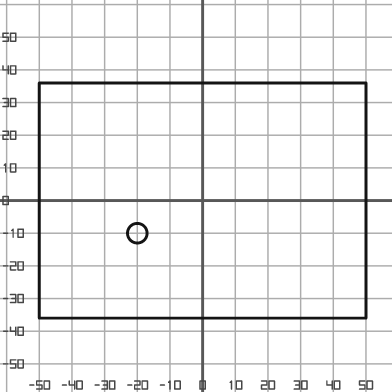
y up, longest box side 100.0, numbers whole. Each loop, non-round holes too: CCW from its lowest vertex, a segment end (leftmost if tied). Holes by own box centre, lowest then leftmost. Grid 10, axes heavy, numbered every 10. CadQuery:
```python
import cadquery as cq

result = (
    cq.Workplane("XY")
    .moveTo(-50.0, -36.0)
    .lineTo(50.0, -36.0)
    .lineTo(50.0, 36.0)
    .lineTo(-50.0, 36.0)
    .close()
    .moveTo(-20.0, -10.0)
    .circle(3.0)
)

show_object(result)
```